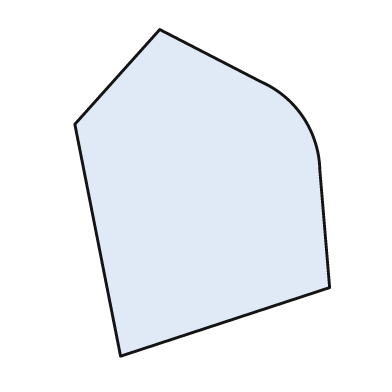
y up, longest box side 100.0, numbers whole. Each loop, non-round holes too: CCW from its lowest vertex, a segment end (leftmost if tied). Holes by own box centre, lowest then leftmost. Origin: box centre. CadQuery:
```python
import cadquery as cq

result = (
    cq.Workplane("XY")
    .moveTo(-25.0, -50.0)
    .lineTo(39.0, -29.0)
    .lineTo(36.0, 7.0)
    .threePointArc((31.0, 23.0), (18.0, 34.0))
    .lineTo(-13.0, 50.0)
    .lineTo(-39.0, 21.0)
    .close()
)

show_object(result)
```